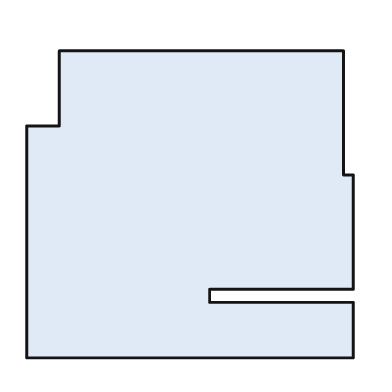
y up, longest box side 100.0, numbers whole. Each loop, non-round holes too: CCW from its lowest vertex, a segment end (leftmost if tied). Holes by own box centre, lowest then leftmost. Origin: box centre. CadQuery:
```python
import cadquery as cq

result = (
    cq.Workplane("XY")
    .moveTo(-50.0, -47.0)
    .lineTo(50.0, -47.0)
    .lineTo(50.0, -30.0)
    .lineTo(6.0, -30.0)
    .lineTo(6.0, -26.0)
    .lineTo(50.0, -26.0)
    .lineTo(50.0, 9.0)
    .lineTo(47.0, 9.0)
    .lineTo(47.0, 47.0)
    .lineTo(-40.0, 47.0)
    .lineTo(-40.0, 24.0)
    .lineTo(-50.0, 24.0)
    .close()
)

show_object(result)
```